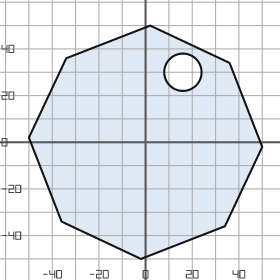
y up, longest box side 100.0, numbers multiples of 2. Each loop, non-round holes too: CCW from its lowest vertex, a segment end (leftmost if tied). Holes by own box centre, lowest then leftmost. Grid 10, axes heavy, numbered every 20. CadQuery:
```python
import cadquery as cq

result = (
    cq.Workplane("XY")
    .moveTo(-2.0, -50.0)
    .lineTo(34.0, -36.0)
    .lineTo(50.0, -2.0)
    .lineTo(36.0, 34.0)
    .lineTo(2.0, 50.0)
    .lineTo(-34.0, 36.0)
    .lineTo(-50.0, 2.0)
    .lineTo(-36.0, -34.0)
    .close()
    .moveTo(16.0, 30.0)
    .circle(8.0)
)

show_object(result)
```